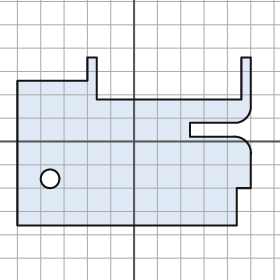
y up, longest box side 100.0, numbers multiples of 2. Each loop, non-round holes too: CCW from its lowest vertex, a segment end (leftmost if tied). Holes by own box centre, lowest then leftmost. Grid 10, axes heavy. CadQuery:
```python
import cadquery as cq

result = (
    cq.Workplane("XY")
    .moveTo(-50.0, -36.0)
    .lineTo(44.0, -36.0)
    .lineTo(44.0, -20.0)
    .lineTo(50.0, -20.0)
    .lineTo(50.0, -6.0)
    .threePointArc((48.0, 0.0), (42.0, 2.0))
    .lineTo(24.0, 2.0)
    .lineTo(24.0, 8.0)
    .lineTo(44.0, 8.0)
    .threePointArc((48.0, 10.0), (50.0, 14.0))
    .lineTo(50.0, 36.0)
    .lineTo(46.0, 36.0)
    .lineTo(46.0, 18.0)
    .lineTo(-16.0, 18.0)
    .lineTo(-16.0, 36.0)
    .lineTo(-20.0, 36.0)
    .lineTo(-20.0, 26.0)
    .lineTo(-50.0, 26.0)
    .close()
    .moveTo(-36.0, -16.0)
    .circle(4.0)
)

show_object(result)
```